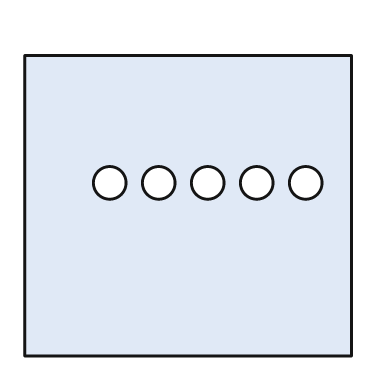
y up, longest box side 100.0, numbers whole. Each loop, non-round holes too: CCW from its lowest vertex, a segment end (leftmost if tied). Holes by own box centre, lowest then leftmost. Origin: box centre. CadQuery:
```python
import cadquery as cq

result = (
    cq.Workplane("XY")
    .moveTo(-50.0, -46.0)
    .lineTo(50.0, -46.0)
    .lineTo(50.0, 46.0)
    .lineTo(-50.0, 46.0)
    .close()
    .moveTo(-24.0, 7.0)
    .circle(5.0)
    .moveTo(-9.0, 7.0)
    .circle(5.0)
    .moveTo(6.0, 7.0)
    .circle(5.0)
    .moveTo(21.0, 7.0)
    .circle(5.0)
    .moveTo(36.0, 7.0)
    .circle(5.0)
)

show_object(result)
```